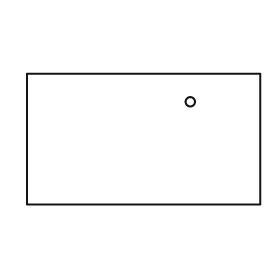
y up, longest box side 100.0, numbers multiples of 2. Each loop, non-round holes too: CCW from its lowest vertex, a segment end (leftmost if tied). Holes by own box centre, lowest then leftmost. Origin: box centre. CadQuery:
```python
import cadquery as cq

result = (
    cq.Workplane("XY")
    .moveTo(-50.0, -28.0)
    .lineTo(50.0, -28.0)
    .lineTo(50.0, 28.0)
    .lineTo(-50.0, 28.0)
    .close()
    .moveTo(20.0, 16.0)
    .circle(2.0)
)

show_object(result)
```